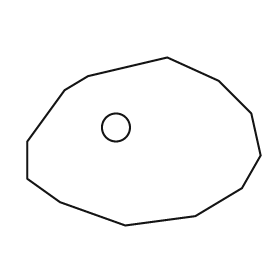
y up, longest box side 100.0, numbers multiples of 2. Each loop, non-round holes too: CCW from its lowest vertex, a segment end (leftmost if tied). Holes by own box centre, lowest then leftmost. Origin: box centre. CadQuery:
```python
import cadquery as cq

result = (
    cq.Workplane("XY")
    .moveTo(-8.0, -36.0)
    .lineTo(22.0, -32.0)
    .lineTo(42.0, -20.0)
    .lineTo(50.0, -6.0)
    .lineTo(46.0, 12.0)
    .lineTo(32.0, 26.0)
    .lineTo(10.0, 36.0)
    .lineTo(-24.0, 28.0)
    .lineTo(-34.0, 22.0)
    .lineTo(-50.0, 0.0)
    .lineTo(-50.0, -16.0)
    .lineTo(-36.0, -26.0)
    .close()
    .moveTo(-12.0, 6.0)
    .circle(6.0)
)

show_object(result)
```